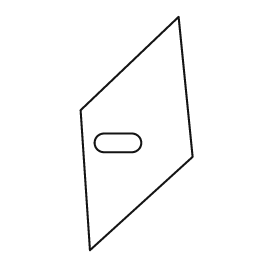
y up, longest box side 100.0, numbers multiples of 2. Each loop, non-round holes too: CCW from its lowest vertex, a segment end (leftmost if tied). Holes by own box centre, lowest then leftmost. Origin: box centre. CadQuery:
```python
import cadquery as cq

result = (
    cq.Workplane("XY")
    .moveTo(-20.0, -50.0)
    .lineTo(24.0, -10.0)
    .lineTo(18.0, 50.0)
    .lineTo(-24.0, 10.0)
    .close()
    .moveTo(-14.0, -8.0)
    .lineTo(-2.0, -8.0)
    .threePointArc((2.0, -4.0), (-2.0, 0.0))
    .lineTo(-14.0, 0.0)
    .threePointArc((-18.0, -4.0), (-14.0, -8.0))
    .close()
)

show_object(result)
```